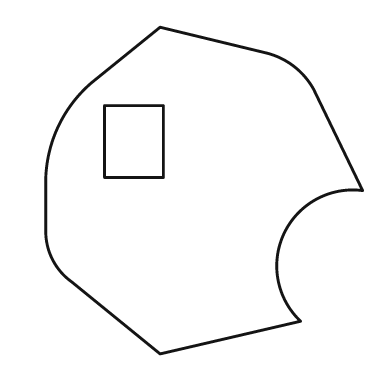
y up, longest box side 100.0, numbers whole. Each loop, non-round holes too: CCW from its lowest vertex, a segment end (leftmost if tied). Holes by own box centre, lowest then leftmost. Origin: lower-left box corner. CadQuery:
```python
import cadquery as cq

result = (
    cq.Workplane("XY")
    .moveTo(35.0, 0.0)
    .lineTo(78.0, 10.0)
    .threePointArc((73.0, 37.0), (97.0, 50.0))
    .lineTo(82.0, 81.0)
    .threePointArc((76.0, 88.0), (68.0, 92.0))
    .lineTo(35.0, 100.0)
    .lineTo(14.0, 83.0)
    .threePointArc((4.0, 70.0), (0.0, 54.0))
    .lineTo(0.0, 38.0)
    .threePointArc((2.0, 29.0), (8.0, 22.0))
    .close()
    .moveTo(18.0, 54.0)
    .lineTo(36.0, 54.0)
    .lineTo(36.0, 76.0)
    .lineTo(18.0, 76.0)
    .close()
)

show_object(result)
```